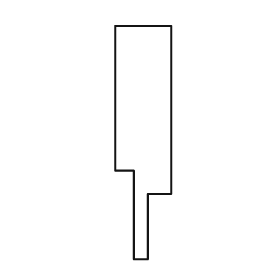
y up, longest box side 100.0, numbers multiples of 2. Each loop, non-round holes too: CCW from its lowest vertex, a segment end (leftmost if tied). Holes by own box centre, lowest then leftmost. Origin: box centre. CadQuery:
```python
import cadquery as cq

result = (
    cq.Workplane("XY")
    .moveTo(-4.0, -50.0)
    .lineTo(2.0, -50.0)
    .lineTo(2.0, -22.0)
    .lineTo(12.0, -22.0)
    .lineTo(12.0, 50.0)
    .lineTo(-12.0, 50.0)
    .lineTo(-12.0, -12.0)
    .lineTo(-4.0, -12.0)
    .close()
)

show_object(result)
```